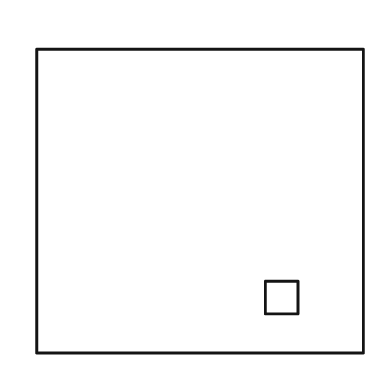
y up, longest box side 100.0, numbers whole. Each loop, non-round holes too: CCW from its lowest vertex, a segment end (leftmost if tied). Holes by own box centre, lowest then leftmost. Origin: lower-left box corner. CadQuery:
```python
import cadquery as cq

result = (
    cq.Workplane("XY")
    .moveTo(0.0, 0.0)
    .lineTo(100.0, 0.0)
    .lineTo(100.0, 93.0)
    .lineTo(0.0, 93.0)
    .close()
    .moveTo(70.0, 12.0)
    .lineTo(80.0, 12.0)
    .lineTo(80.0, 22.0)
    .lineTo(70.0, 22.0)
    .close()
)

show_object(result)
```